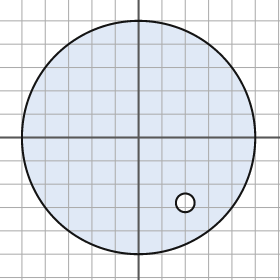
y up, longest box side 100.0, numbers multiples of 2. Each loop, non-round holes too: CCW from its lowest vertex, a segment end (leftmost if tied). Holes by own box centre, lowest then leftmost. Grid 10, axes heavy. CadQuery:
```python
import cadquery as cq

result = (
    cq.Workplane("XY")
    .moveTo(0.0, 0.0)
    .circle(50.0)
    .moveTo(20.0, -28.0)
    .circle(4.0)
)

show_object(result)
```